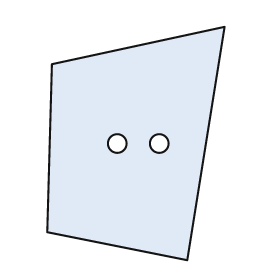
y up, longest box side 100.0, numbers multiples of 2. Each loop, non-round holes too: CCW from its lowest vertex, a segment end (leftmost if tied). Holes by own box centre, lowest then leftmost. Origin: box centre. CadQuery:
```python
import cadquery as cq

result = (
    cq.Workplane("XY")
    .moveTo(22.0, -50.0)
    .lineTo(38.0, 50.0)
    .lineTo(-36.0, 34.0)
    .lineTo(-38.0, -38.0)
    .close()
    .moveTo(-8.0, 0.0)
    .circle(4.0)
    .moveTo(10.0, 0.0)
    .circle(4.0)
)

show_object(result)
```